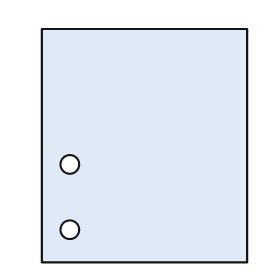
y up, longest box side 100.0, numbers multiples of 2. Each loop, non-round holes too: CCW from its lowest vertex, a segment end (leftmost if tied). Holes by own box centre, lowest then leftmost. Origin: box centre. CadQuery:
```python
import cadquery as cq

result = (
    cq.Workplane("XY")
    .moveTo(-44.0, -50.0)
    .lineTo(44.0, -50.0)
    .lineTo(44.0, 50.0)
    .lineTo(-44.0, 50.0)
    .close()
    .moveTo(-32.0, -36.0)
    .circle(4.0)
    .moveTo(-32.0, -8.0)
    .circle(4.0)
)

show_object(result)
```